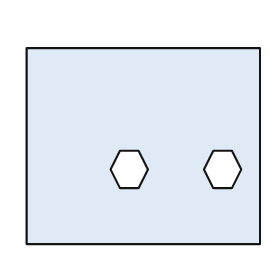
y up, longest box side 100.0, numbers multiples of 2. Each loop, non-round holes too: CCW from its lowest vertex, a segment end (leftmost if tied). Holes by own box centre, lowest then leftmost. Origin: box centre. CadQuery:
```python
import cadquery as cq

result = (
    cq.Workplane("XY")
    .moveTo(-50.0, -42.0)
    .lineTo(50.0, -42.0)
    .lineTo(50.0, 42.0)
    .lineTo(-50.0, 42.0)
    .close()
    .moveTo(-10.0, -18.0)
    .lineTo(-2.0, -18.0)
    .lineTo(2.0, -10.0)
    .lineTo(-2.0, -2.0)
    .lineTo(-10.0, -2.0)
    .lineTo(-14.0, -10.0)
    .close()
    .moveTo(30.0, -18.0)
    .lineTo(38.0, -18.0)
    .lineTo(42.0, -10.0)
    .lineTo(38.0, -2.0)
    .lineTo(30.0, -2.0)
    .lineTo(26.0, -10.0)
    .close()
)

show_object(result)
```